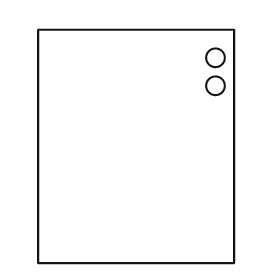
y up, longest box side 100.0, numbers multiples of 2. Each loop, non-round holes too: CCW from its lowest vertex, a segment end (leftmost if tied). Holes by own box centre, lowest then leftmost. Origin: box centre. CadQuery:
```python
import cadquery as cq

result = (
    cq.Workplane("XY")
    .moveTo(-42.0, -50.0)
    .lineTo(42.0, -50.0)
    .lineTo(42.0, 50.0)
    .lineTo(-42.0, 50.0)
    .close()
    .moveTo(34.0, 26.0)
    .circle(4.0)
    .moveTo(34.0, 38.0)
    .circle(4.0)
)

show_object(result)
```